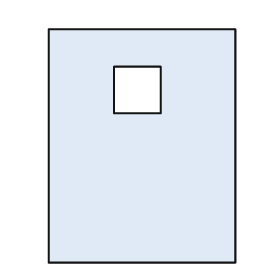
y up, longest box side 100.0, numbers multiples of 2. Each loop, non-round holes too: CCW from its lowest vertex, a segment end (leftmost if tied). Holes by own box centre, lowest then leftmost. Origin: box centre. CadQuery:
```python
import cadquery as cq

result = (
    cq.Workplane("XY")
    .moveTo(-40.0, -50.0)
    .lineTo(40.0, -50.0)
    .lineTo(40.0, 50.0)
    .lineTo(-40.0, 50.0)
    .close()
    .moveTo(-12.0, 14.0)
    .lineTo(8.0, 14.0)
    .lineTo(8.0, 34.0)
    .lineTo(-12.0, 34.0)
    .close()
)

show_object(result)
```